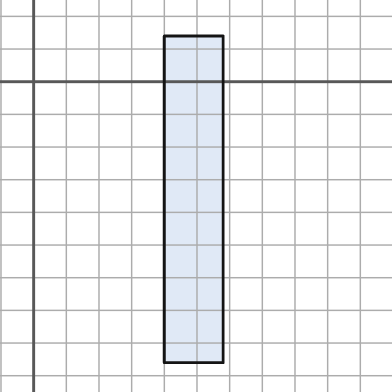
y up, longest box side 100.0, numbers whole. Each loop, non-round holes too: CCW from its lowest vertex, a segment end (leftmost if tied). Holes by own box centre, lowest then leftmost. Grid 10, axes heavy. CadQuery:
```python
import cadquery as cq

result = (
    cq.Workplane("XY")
    .moveTo(40.0, -86.0)
    .lineTo(58.0, -86.0)
    .lineTo(58.0, 14.0)
    .lineTo(40.0, 14.0)
    .close()
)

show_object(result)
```